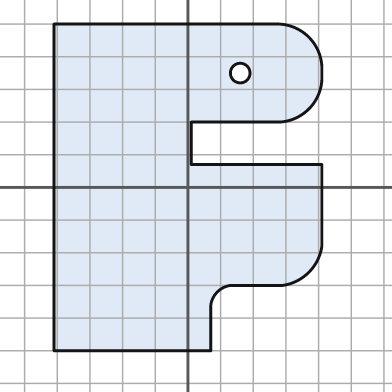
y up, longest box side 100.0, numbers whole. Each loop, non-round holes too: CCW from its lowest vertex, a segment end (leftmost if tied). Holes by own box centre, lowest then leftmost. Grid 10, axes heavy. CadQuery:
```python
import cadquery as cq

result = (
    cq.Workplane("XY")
    .moveTo(-41.0, -50.0)
    .lineTo(7.0, -50.0)
    .lineTo(7.0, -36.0)
    .threePointArc((9.0, -32.0), (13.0, -30.0))
    .lineTo(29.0, -30.0)
    .threePointArc((37.0, -26.0), (41.0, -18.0))
    .lineTo(41.0, 7.0)
    .lineTo(1.0, 7.0)
    .lineTo(1.0, 20.0)
    .lineTo(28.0, 20.0)
    .threePointArc((37.0, 24.0), (41.0, 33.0))
    .lineTo(41.0, 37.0)
    .threePointArc((37.0, 46.0), (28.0, 50.0))
    .lineTo(-41.0, 50.0)
    .close()
    .moveTo(16.0, 35.0)
    .circle(3.0)
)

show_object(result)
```